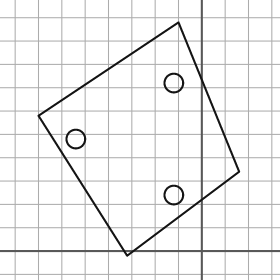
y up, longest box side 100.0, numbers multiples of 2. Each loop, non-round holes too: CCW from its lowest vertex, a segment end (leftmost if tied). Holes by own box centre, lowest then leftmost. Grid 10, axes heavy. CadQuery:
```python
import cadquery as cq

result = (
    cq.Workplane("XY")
    .moveTo(-32.0, -2.0)
    .lineTo(16.0, 34.0)
    .lineTo(-10.0, 98.0)
    .lineTo(-70.0, 58.0)
    .close()
    .moveTo(-12.0, 24.0)
    .circle(4.0)
    .moveTo(-54.0, 48.0)
    .circle(4.0)
    .moveTo(-12.0, 72.0)
    .circle(4.0)
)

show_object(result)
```